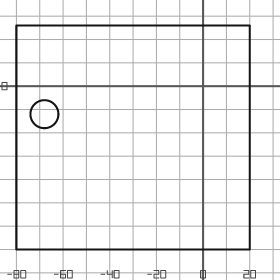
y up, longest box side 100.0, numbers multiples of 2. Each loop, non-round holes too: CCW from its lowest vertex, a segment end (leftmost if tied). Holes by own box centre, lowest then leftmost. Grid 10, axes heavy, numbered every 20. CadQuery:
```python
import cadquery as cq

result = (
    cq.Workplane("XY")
    .moveTo(-80.0, -70.0)
    .lineTo(20.0, -70.0)
    .lineTo(20.0, 26.0)
    .lineTo(-80.0, 26.0)
    .close()
    .moveTo(-68.0, -12.0)
    .circle(6.0)
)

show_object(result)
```